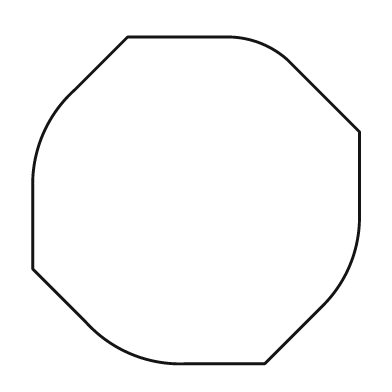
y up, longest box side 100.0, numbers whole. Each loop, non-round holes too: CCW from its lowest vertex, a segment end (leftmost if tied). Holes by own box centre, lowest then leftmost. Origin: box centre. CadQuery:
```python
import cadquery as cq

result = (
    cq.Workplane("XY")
    .moveTo(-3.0, -50.0)
    .lineTo(21.0, -50.0)
    .lineTo(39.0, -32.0)
    .threePointArc((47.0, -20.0), (50.0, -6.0))
    .lineTo(50.0, 21.0)
    .lineTo(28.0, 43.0)
    .threePointArc((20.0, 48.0), (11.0, 50.0))
    .lineTo(-21.0, 50.0)
    .lineTo(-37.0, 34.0)
    .threePointArc((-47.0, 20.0), (-50.0, 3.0))
    .lineTo(-50.0, -21.0)
    .lineTo(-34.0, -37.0)
    .threePointArc((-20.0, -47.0), (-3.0, -50.0))
    .close()
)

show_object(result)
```